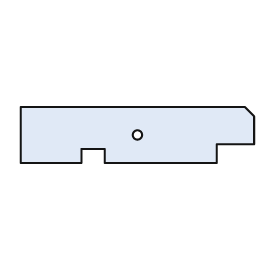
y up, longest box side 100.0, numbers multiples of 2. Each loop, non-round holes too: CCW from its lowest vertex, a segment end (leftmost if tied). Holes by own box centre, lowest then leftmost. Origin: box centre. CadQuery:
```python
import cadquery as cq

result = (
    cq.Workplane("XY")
    .moveTo(-50.0, -12.0)
    .lineTo(-24.0, -12.0)
    .lineTo(-24.0, -6.0)
    .lineTo(-14.0, -6.0)
    .lineTo(-14.0, -12.0)
    .lineTo(34.0, -12.0)
    .lineTo(34.0, -4.0)
    .lineTo(50.0, -4.0)
    .lineTo(50.0, 8.0)
    .lineTo(46.0, 12.0)
    .lineTo(-50.0, 12.0)
    .close()
    .moveTo(0.0, 0.0)
    .circle(2.0)
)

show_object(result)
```